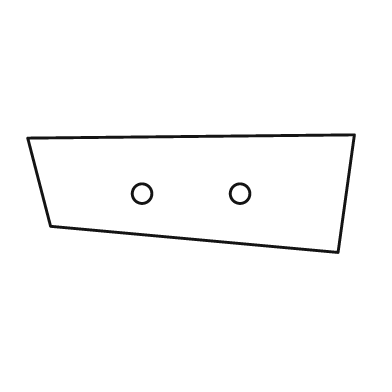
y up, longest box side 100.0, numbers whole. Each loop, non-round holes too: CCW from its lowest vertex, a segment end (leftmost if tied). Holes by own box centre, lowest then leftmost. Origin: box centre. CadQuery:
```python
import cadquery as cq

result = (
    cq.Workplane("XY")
    .moveTo(45.0, -18.0)
    .lineTo(50.0, 18.0)
    .lineTo(-50.0, 17.0)
    .lineTo(-43.0, -10.0)
    .close()
    .moveTo(-15.0, 0.0)
    .circle(3.0)
    .moveTo(15.0, 0.0)
    .circle(3.0)
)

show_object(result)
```